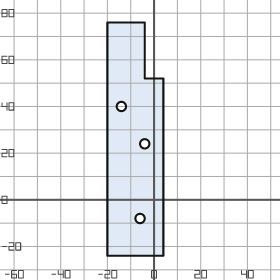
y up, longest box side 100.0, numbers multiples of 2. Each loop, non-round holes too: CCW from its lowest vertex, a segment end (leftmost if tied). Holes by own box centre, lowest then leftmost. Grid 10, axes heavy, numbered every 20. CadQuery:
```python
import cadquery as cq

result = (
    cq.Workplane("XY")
    .moveTo(-20.0, -24.0)
    .lineTo(4.0, -24.0)
    .lineTo(4.0, 52.0)
    .lineTo(-4.0, 52.0)
    .lineTo(-4.0, 76.0)
    .lineTo(-20.0, 76.0)
    .close()
    .moveTo(-6.0, -8.0)
    .circle(2.0)
    .moveTo(-4.0, 24.0)
    .circle(2.0)
    .moveTo(-14.0, 40.0)
    .circle(2.0)
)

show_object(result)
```